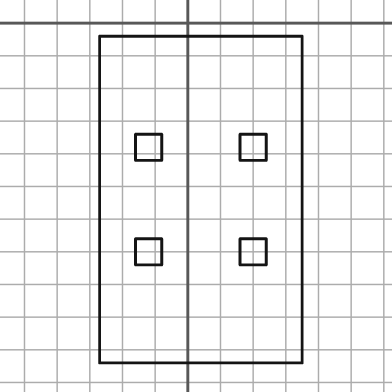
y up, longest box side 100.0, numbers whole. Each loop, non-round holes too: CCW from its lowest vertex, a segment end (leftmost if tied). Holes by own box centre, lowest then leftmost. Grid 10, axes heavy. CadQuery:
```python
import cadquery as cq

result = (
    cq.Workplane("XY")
    .moveTo(-27.0, -104.0)
    .lineTo(35.0, -104.0)
    .lineTo(35.0, -4.0)
    .lineTo(-27.0, -4.0)
    .close()
    .moveTo(-16.0, -74.0)
    .lineTo(-8.0, -74.0)
    .lineTo(-8.0, -66.0)
    .lineTo(-16.0, -66.0)
    .close()
    .moveTo(16.0, -74.0)
    .lineTo(24.0, -74.0)
    .lineTo(24.0, -66.0)
    .lineTo(16.0, -66.0)
    .close()
    .moveTo(-16.0, -42.0)
    .lineTo(-8.0, -42.0)
    .lineTo(-8.0, -34.0)
    .lineTo(-16.0, -34.0)
    .close()
    .moveTo(16.0, -42.0)
    .lineTo(24.0, -42.0)
    .lineTo(24.0, -34.0)
    .lineTo(16.0, -34.0)
    .close()
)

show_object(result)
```